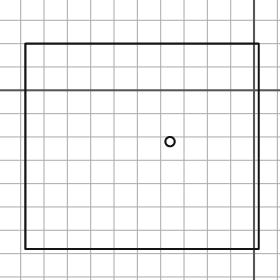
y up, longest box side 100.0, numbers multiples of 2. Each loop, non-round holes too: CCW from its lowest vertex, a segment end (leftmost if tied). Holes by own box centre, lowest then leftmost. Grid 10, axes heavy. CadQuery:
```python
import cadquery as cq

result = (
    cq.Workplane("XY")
    .moveTo(-98.0, -68.0)
    .lineTo(2.0, -68.0)
    .lineTo(2.0, 20.0)
    .lineTo(-98.0, 20.0)
    .close()
    .moveTo(-36.0, -22.0)
    .circle(2.0)
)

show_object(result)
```